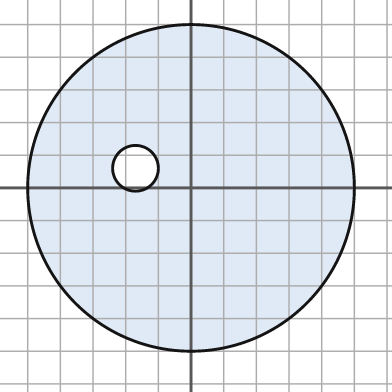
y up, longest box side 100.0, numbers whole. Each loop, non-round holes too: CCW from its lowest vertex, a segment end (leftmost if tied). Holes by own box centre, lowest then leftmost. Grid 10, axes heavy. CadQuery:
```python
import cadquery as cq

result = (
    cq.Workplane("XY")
    .moveTo(0.0, 0.0)
    .circle(50.0)
    .moveTo(-17.0, 6.0)
    .circle(7.0)
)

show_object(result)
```